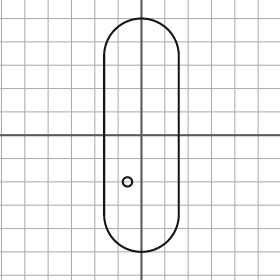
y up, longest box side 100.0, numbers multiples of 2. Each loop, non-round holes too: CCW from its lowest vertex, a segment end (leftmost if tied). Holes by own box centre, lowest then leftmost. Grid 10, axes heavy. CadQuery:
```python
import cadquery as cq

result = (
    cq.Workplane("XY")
    .moveTo(-16.0, -34.0)
    .threePointArc((0.0, -50.0), (16.0, -34.0))
    .lineTo(16.0, 34.0)
    .threePointArc((0.0, 50.0), (-16.0, 34.0))
    .close()
    .moveTo(-6.0, -20.0)
    .circle(2.0)
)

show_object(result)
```